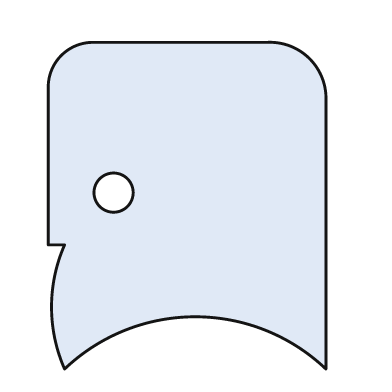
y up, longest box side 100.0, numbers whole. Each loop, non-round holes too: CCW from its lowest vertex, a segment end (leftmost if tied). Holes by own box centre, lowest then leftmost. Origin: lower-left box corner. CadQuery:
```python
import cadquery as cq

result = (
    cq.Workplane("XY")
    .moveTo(5.0, 0.0)
    .threePointArc((45.0, 16.0), (85.0, 0.0))
    .lineTo(85.0, 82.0)
    .threePointArc((80.0, 95.0), (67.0, 100.0))
    .lineTo(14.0, 100.0)
    .threePointArc((4.0, 96.0), (0.0, 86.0))
    .lineTo(0.0, 38.0)
    .lineTo(5.0, 38.0)
    .threePointArc((1.0, 19.0), (5.0, 0.0))
    .close()
    .moveTo(20.0, 54.0)
    .circle(6.0)
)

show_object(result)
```